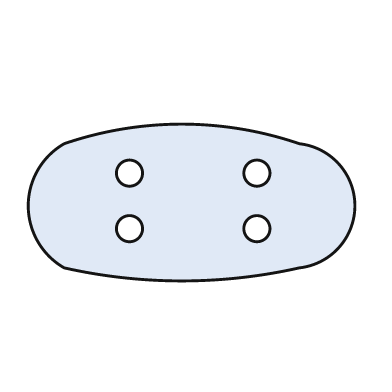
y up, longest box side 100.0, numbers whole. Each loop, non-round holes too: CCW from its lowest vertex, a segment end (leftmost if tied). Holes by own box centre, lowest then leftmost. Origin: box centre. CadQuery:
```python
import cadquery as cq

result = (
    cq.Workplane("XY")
    .moveTo(-39.0, -20.0)
    .threePointArc((-3.0, -24.0), (33.0, -20.0))
    .threePointArc((50.0, -1.0), (33.0, 18.0))
    .threePointArc((-3.0, 24.0), (-39.0, 18.0))
    .threePointArc((-50.0, -1.0), (-39.0, -20.0))
    .close()
    .moveTo(-19.0, -8.0)
    .circle(4.0)
    .moveTo(20.0, -8.0)
    .circle(4.0)
    .moveTo(-19.0, 9.0)
    .circle(4.0)
    .moveTo(20.0, 9.0)
    .circle(4.0)
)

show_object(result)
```